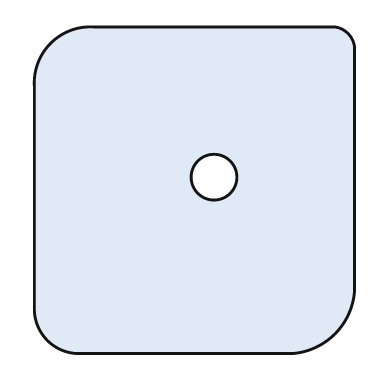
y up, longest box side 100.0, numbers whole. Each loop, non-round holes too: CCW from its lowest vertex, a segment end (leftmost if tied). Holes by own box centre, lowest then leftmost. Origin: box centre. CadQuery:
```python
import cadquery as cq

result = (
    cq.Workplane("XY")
    .moveTo(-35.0, -50.0)
    .lineTo(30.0, -50.0)
    .threePointArc((43.0, -44.0), (49.0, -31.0))
    .lineTo(49.0, 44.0)
    .threePointArc((47.0, 48.0), (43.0, 50.0))
    .lineTo(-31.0, 50.0)
    .threePointArc((-44.0, 45.0), (-49.0, 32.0))
    .lineTo(-49.0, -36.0)
    .threePointArc((-45.0, -46.0), (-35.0, -50.0))
    .close()
    .moveTo(6.0, 4.0)
    .circle(7.0)
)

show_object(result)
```